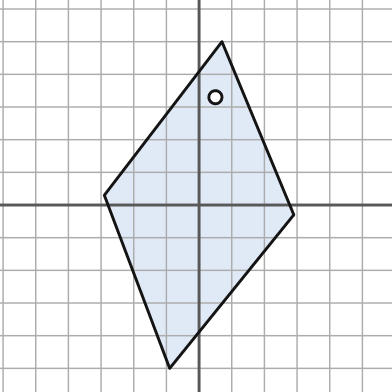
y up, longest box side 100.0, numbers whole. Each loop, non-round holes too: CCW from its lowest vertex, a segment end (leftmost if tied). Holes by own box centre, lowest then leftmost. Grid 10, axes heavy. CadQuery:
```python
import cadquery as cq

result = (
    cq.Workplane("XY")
    .moveTo(-9.0, -50.0)
    .lineTo(29.0, -3.0)
    .lineTo(7.0, 50.0)
    .lineTo(-29.0, 3.0)
    .close()
    .moveTo(5.0, 33.0)
    .circle(2.0)
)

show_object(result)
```